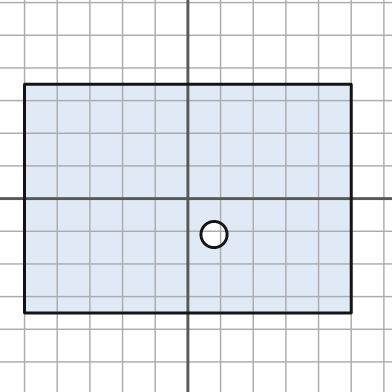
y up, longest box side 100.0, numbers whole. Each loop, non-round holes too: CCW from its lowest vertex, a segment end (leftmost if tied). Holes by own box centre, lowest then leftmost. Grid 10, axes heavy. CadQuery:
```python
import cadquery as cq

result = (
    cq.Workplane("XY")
    .moveTo(-50.0, -35.0)
    .lineTo(50.0, -35.0)
    .lineTo(50.0, 35.0)
    .lineTo(-50.0, 35.0)
    .close()
    .moveTo(8.0, -11.0)
    .circle(4.0)
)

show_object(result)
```